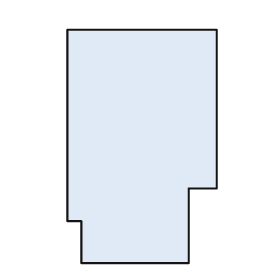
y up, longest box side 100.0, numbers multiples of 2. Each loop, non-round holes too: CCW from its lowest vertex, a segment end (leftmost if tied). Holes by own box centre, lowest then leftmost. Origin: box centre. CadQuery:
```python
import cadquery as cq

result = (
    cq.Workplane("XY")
    .moveTo(-26.0, -50.0)
    .lineTo(20.0, -50.0)
    .lineTo(20.0, -18.0)
    .lineTo(32.0, -18.0)
    .lineTo(32.0, 50.0)
    .lineTo(-32.0, 50.0)
    .lineTo(-32.0, -32.0)
    .lineTo(-26.0, -32.0)
    .close()
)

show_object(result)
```